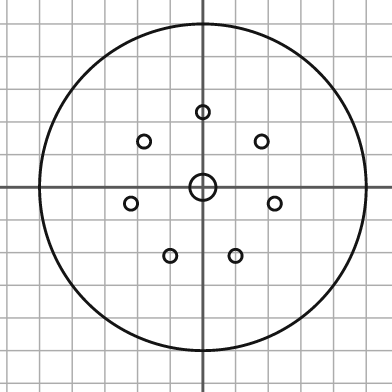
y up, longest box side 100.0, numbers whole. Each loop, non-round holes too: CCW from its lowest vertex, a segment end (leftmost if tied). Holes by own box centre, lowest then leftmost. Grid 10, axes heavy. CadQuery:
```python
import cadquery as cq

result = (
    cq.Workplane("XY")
    .moveTo(0.0, 0.0)
    .circle(50.0)
    .moveTo(-10.0, -21.0)
    .circle(2.0)
    .moveTo(10.0, -21.0)
    .circle(2.0)
    .moveTo(-22.0, -5.0)
    .circle(2.0)
    .moveTo(22.0, -5.0)
    .circle(2.0)
    .moveTo(0.0, 0.0)
    .circle(4.0)
    .moveTo(-18.0, 14.0)
    .circle(2.0)
    .moveTo(18.0, 14.0)
    .circle(2.0)
    .moveTo(0.0, 23.0)
    .circle(2.0)
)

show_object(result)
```